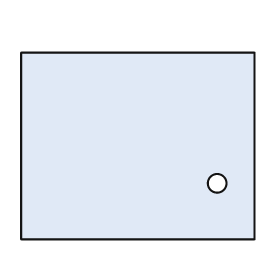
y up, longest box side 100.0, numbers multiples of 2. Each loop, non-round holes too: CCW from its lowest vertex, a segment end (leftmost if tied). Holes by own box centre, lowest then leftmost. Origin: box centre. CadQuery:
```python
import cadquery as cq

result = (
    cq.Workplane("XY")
    .moveTo(-50.0, -40.0)
    .lineTo(50.0, -40.0)
    .lineTo(50.0, 40.0)
    .lineTo(-50.0, 40.0)
    .close()
    .moveTo(34.0, -16.0)
    .circle(4.0)
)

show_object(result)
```